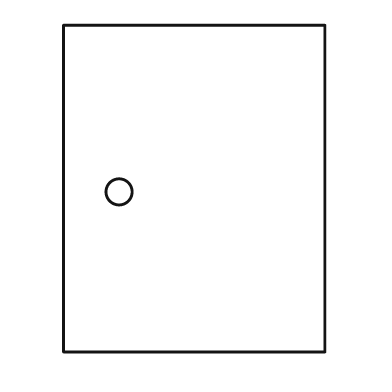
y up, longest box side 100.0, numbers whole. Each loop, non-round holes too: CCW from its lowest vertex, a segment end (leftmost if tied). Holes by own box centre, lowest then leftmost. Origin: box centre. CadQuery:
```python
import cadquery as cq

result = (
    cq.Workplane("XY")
    .moveTo(-40.0, -50.0)
    .lineTo(40.0, -50.0)
    .lineTo(40.0, 50.0)
    .lineTo(-40.0, 50.0)
    .close()
    .moveTo(-23.0, -1.0)
    .circle(4.0)
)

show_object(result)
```